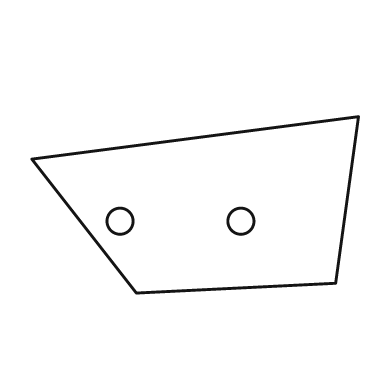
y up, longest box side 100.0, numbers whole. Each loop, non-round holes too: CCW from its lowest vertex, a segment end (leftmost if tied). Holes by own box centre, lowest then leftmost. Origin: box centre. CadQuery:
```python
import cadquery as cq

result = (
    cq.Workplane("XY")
    .moveTo(-18.0, -27.0)
    .lineTo(43.0, -24.0)
    .lineTo(50.0, 27.0)
    .lineTo(-50.0, 14.0)
    .close()
    .moveTo(-23.0, -5.0)
    .circle(4.0)
    .moveTo(14.0, -5.0)
    .circle(4.0)
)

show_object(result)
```